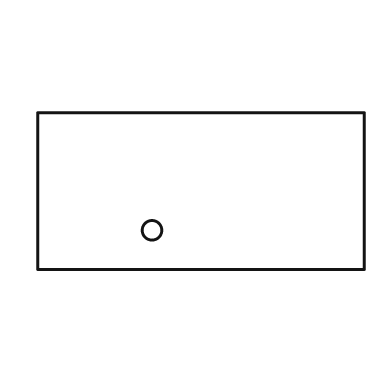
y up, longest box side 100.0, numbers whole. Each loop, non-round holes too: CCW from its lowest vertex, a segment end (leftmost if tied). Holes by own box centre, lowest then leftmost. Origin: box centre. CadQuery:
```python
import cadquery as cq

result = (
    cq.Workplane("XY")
    .moveTo(-50.0, -24.0)
    .lineTo(50.0, -24.0)
    .lineTo(50.0, 24.0)
    .lineTo(-50.0, 24.0)
    .close()
    .moveTo(-15.0, -12.0)
    .circle(3.0)
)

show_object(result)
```